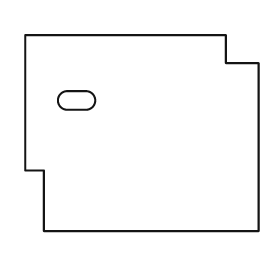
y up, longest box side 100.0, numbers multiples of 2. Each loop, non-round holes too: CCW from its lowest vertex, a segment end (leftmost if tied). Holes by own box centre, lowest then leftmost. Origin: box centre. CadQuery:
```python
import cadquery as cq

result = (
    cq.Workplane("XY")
    .moveTo(-42.0, -42.0)
    .lineTo(50.0, -42.0)
    .lineTo(50.0, 30.0)
    .lineTo(36.0, 30.0)
    .lineTo(36.0, 42.0)
    .lineTo(-50.0, 42.0)
    .lineTo(-50.0, -16.0)
    .lineTo(-42.0, -16.0)
    .close()
    .moveTo(-32.0, 10.0)
    .lineTo(-24.0, 10.0)
    .threePointArc((-20.0, 14.0), (-24.0, 18.0))
    .lineTo(-32.0, 18.0)
    .threePointArc((-36.0, 14.0), (-32.0, 10.0))
    .close()
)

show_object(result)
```